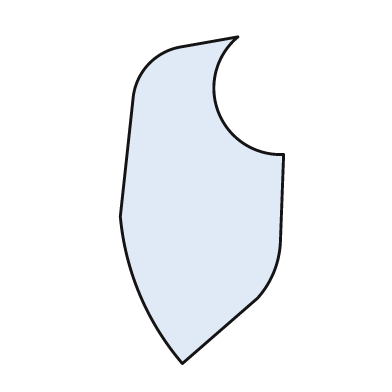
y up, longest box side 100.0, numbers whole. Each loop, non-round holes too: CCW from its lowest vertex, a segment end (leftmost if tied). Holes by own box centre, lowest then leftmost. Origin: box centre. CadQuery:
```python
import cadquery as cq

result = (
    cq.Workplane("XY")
    .moveTo(-6.0, -50.0)
    .lineTo(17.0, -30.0)
    .threePointArc((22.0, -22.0), (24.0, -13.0))
    .lineTo(25.0, 14.0)
    .threePointArc((5.0, 27.0), (11.0, 50.0))
    .lineTo(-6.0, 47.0)
    .threePointArc((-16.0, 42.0), (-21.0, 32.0))
    .lineTo(-25.0, -5.0)
    .threePointArc((-19.0, -29.0), (-6.0, -50.0))
    .close()
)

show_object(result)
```